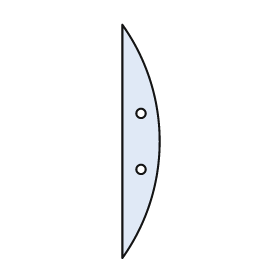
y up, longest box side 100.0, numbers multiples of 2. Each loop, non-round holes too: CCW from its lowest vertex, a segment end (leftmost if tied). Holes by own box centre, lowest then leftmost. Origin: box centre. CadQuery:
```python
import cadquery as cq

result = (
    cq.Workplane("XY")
    .moveTo(-8.0, -50.0)
    .threePointArc((8.0, 0.0), (-8.0, 50.0))
    .close()
    .moveTo(0.0, -12.0)
    .circle(2.0)
    .moveTo(0.0, 12.0)
    .circle(2.0)
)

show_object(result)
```